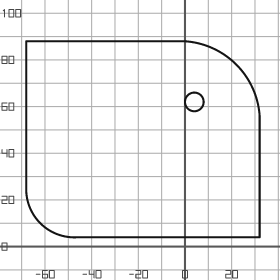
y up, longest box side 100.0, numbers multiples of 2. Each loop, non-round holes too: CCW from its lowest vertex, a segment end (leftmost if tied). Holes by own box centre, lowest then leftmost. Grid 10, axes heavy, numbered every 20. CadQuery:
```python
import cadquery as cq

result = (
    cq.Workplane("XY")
    .moveTo(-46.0, 4.0)
    .lineTo(32.0, 4.0)
    .lineTo(32.0, 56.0)
    .threePointArc((22.0, 78.0), (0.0, 88.0))
    .lineTo(-68.0, 88.0)
    .lineTo(-68.0, 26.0)
    .threePointArc((-62.0, 10.0), (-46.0, 4.0))
    .close()
    .moveTo(4.0, 62.0)
    .circle(4.0)
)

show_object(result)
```